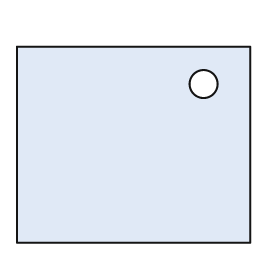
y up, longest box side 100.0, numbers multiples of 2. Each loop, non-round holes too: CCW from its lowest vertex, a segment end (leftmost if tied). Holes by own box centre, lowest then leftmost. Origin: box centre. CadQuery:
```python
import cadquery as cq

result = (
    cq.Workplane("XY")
    .moveTo(-50.0, -42.0)
    .lineTo(50.0, -42.0)
    .lineTo(50.0, 42.0)
    .lineTo(-50.0, 42.0)
    .close()
    .moveTo(30.0, 26.0)
    .circle(6.0)
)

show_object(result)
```